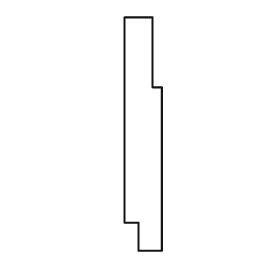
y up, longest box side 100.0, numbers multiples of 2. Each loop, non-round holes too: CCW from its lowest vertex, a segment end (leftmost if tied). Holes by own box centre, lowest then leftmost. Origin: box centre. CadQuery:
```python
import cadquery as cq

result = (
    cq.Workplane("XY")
    .moveTo(-2.0, -50.0)
    .lineTo(8.0, -50.0)
    .lineTo(8.0, 20.0)
    .lineTo(4.0, 20.0)
    .lineTo(4.0, 50.0)
    .lineTo(-8.0, 50.0)
    .lineTo(-8.0, -38.0)
    .lineTo(-2.0, -38.0)
    .close()
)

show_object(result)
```